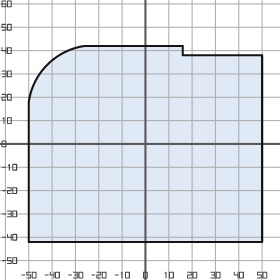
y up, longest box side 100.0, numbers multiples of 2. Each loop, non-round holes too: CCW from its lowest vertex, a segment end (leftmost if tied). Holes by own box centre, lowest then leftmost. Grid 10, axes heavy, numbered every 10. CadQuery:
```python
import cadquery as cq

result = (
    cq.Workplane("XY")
    .moveTo(-50.0, -42.0)
    .lineTo(50.0, -42.0)
    .lineTo(50.0, 38.0)
    .lineTo(16.0, 38.0)
    .lineTo(16.0, 42.0)
    .lineTo(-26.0, 42.0)
    .threePointArc((-42.0, 34.0), (-50.0, 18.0))
    .close()
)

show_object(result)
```